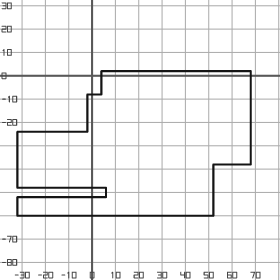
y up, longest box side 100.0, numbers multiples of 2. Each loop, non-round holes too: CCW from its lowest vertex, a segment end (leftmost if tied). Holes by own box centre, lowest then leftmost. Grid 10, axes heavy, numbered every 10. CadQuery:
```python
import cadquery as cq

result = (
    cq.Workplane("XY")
    .moveTo(-32.0, -60.0)
    .lineTo(52.0, -60.0)
    .lineTo(52.0, -38.0)
    .lineTo(68.0, -38.0)
    .lineTo(68.0, 2.0)
    .lineTo(4.0, 2.0)
    .lineTo(4.0, -8.0)
    .lineTo(-2.0, -8.0)
    .lineTo(-2.0, -24.0)
    .lineTo(-32.0, -24.0)
    .lineTo(-32.0, -48.0)
    .lineTo(6.0, -48.0)
    .lineTo(6.0, -52.0)
    .lineTo(-32.0, -52.0)
    .close()
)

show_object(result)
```